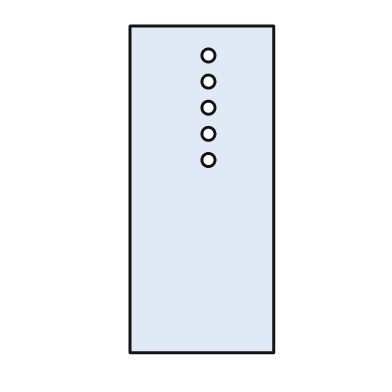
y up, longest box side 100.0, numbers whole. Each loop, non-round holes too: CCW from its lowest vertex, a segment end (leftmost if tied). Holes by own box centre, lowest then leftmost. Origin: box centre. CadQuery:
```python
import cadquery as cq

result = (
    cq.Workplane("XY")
    .moveTo(-22.0, -50.0)
    .lineTo(22.0, -50.0)
    .lineTo(22.0, 50.0)
    .lineTo(-22.0, 50.0)
    .close()
    .moveTo(2.0, 9.0)
    .circle(2.0)
    .moveTo(2.0, 17.0)
    .circle(2.0)
    .moveTo(2.0, 25.0)
    .circle(2.0)
    .moveTo(2.0, 33.0)
    .circle(2.0)
    .moveTo(2.0, 41.0)
    .circle(2.0)
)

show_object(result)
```